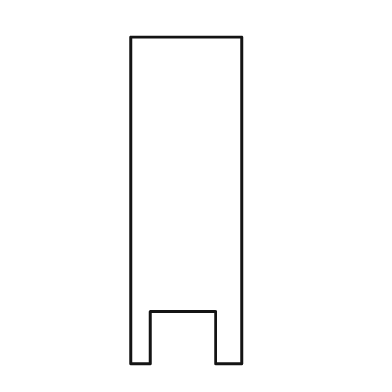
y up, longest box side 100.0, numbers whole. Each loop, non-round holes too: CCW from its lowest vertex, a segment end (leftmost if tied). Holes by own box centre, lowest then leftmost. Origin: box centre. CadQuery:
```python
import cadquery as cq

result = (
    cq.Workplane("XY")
    .moveTo(-17.0, -50.0)
    .lineTo(-11.0, -50.0)
    .lineTo(-11.0, -34.0)
    .lineTo(9.0, -34.0)
    .lineTo(9.0, -50.0)
    .lineTo(17.0, -50.0)
    .lineTo(17.0, 50.0)
    .lineTo(-17.0, 50.0)
    .close()
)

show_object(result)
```